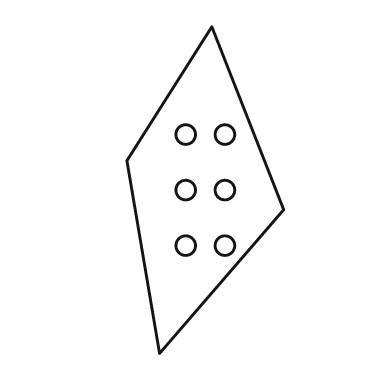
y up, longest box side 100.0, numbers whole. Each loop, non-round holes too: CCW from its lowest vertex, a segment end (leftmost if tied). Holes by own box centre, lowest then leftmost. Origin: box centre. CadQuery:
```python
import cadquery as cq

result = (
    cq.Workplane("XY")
    .moveTo(-14.0, -50.0)
    .lineTo(24.0, -6.0)
    .lineTo(2.0, 50.0)
    .lineTo(-24.0, 9.0)
    .close()
    .moveTo(-6.0, -17.0)
    .circle(3.0)
    .moveTo(6.0, -17.0)
    .circle(3.0)
    .moveTo(-6.0, 0.0)
    .circle(3.0)
    .moveTo(6.0, 0.0)
    .circle(3.0)
    .moveTo(-6.0, 17.0)
    .circle(3.0)
    .moveTo(6.0, 17.0)
    .circle(3.0)
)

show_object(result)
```